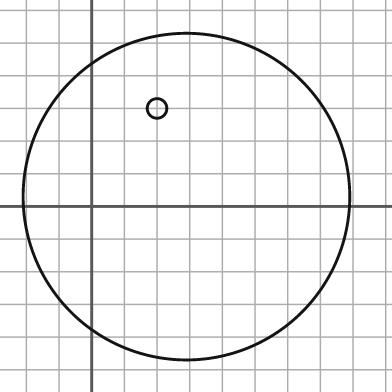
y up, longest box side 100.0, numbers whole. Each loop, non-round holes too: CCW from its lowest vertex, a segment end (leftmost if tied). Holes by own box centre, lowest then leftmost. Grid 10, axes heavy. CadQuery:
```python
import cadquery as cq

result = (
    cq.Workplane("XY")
    .moveTo(29.0, 3.0)
    .circle(50.0)
    .moveTo(20.0, 30.0)
    .circle(3.0)
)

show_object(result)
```